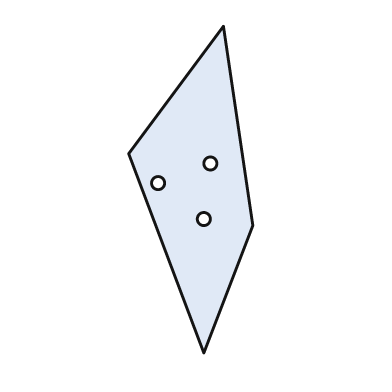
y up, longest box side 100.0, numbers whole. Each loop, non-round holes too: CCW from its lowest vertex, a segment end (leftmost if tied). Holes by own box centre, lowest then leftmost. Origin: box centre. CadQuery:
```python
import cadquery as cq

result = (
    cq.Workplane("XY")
    .moveTo(4.0, -50.0)
    .lineTo(19.0, -11.0)
    .lineTo(10.0, 50.0)
    .lineTo(-19.0, 11.0)
    .close()
    .moveTo(4.0, -9.0)
    .circle(2.0)
    .moveTo(-10.0, 2.0)
    .circle(2.0)
    .moveTo(6.0, 8.0)
    .circle(2.0)
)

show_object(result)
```